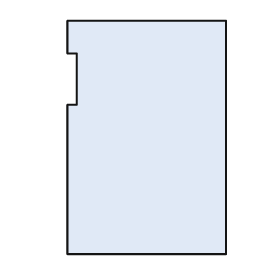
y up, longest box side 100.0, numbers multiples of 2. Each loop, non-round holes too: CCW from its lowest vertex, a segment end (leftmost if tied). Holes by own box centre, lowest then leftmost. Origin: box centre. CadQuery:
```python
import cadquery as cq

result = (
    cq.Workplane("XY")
    .moveTo(-34.0, -50.0)
    .lineTo(34.0, -50.0)
    .lineTo(34.0, 50.0)
    .lineTo(-34.0, 50.0)
    .lineTo(-34.0, 36.0)
    .lineTo(-30.0, 36.0)
    .lineTo(-30.0, 14.0)
    .lineTo(-34.0, 14.0)
    .close()
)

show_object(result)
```